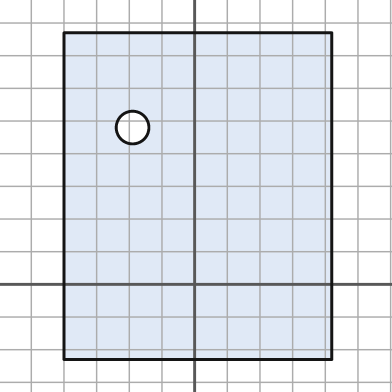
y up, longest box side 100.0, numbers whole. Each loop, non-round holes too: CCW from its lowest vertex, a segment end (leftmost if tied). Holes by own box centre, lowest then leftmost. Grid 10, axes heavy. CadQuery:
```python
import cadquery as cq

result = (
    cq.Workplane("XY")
    .moveTo(-40.0, -23.0)
    .lineTo(42.0, -23.0)
    .lineTo(42.0, 77.0)
    .lineTo(-40.0, 77.0)
    .close()
    .moveTo(-19.0, 48.0)
    .circle(5.0)
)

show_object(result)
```